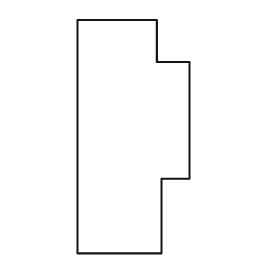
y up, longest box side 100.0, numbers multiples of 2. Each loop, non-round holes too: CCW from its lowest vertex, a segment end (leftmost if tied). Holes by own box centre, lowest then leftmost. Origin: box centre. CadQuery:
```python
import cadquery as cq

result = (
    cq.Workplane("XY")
    .moveTo(-24.0, -50.0)
    .lineTo(12.0, -50.0)
    .lineTo(12.0, -18.0)
    .lineTo(24.0, -18.0)
    .lineTo(24.0, 32.0)
    .lineTo(10.0, 32.0)
    .lineTo(10.0, 50.0)
    .lineTo(-24.0, 50.0)
    .close()
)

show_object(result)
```